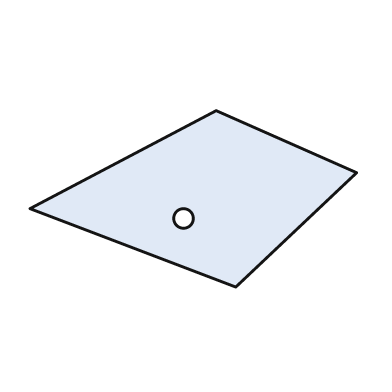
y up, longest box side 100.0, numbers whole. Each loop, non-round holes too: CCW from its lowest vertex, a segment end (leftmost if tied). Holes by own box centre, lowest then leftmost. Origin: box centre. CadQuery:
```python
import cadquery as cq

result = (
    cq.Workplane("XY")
    .moveTo(13.0, -27.0)
    .lineTo(50.0, 8.0)
    .lineTo(7.0, 27.0)
    .lineTo(-50.0, -3.0)
    .close()
    .moveTo(-3.0, -6.0)
    .circle(3.0)
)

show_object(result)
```